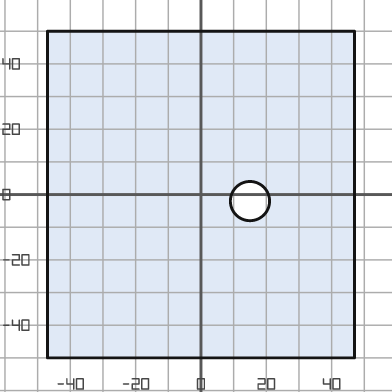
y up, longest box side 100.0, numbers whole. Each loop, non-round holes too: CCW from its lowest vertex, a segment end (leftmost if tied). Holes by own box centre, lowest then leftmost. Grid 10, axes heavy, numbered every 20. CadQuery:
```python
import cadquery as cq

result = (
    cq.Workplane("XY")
    .moveTo(-47.0, -50.0)
    .lineTo(47.0, -50.0)
    .lineTo(47.0, 50.0)
    .lineTo(-47.0, 50.0)
    .close()
    .moveTo(15.0, -2.0)
    .circle(6.0)
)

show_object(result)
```